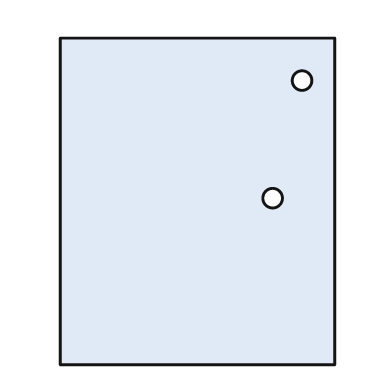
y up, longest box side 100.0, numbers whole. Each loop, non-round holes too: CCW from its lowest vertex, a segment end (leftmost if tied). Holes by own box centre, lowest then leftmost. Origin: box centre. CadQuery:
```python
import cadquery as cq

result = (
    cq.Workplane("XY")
    .moveTo(-42.0, -50.0)
    .lineTo(42.0, -50.0)
    .lineTo(42.0, 50.0)
    .lineTo(-42.0, 50.0)
    .close()
    .moveTo(23.0, 1.0)
    .circle(3.0)
    .moveTo(32.0, 37.0)
    .circle(3.0)
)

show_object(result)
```